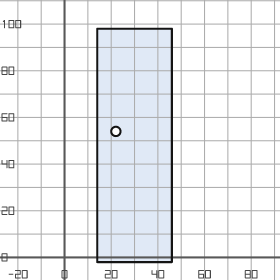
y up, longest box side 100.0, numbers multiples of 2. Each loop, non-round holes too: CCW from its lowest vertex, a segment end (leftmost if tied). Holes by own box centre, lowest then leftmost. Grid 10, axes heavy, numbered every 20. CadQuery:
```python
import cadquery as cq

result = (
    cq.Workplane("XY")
    .moveTo(14.0, -2.0)
    .lineTo(46.0, -2.0)
    .lineTo(46.0, 98.0)
    .lineTo(14.0, 98.0)
    .close()
    .moveTo(22.0, 54.0)
    .circle(2.0)
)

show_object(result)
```